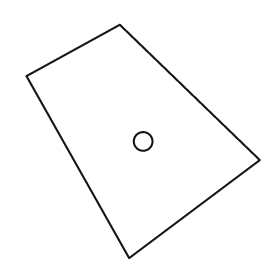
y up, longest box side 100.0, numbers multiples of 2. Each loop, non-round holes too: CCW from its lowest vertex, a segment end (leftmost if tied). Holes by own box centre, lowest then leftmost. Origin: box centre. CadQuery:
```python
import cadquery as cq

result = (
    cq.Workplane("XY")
    .moveTo(-6.0, -50.0)
    .lineTo(50.0, -8.0)
    .lineTo(-10.0, 50.0)
    .lineTo(-50.0, 28.0)
    .close()
    .moveTo(0.0, 0.0)
    .circle(4.0)
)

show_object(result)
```